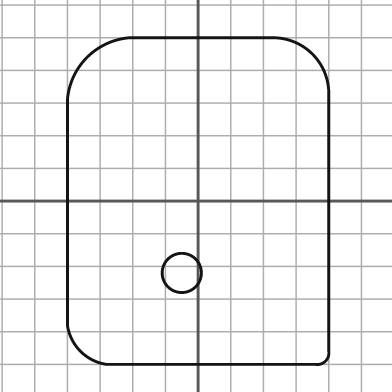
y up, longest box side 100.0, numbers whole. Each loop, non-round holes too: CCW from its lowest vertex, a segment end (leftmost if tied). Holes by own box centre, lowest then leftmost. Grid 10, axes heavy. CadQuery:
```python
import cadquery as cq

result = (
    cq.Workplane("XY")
    .moveTo(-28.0, -50.0)
    .lineTo(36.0, -50.0)
    .threePointArc((39.0, -49.0), (40.0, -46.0))
    .lineTo(40.0, 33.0)
    .threePointArc((35.0, 45.0), (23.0, 50.0))
    .lineTo(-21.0, 50.0)
    .threePointArc((-34.0, 44.0), (-40.0, 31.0))
    .lineTo(-40.0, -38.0)
    .threePointArc((-36.0, -46.0), (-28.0, -50.0))
    .close()
    .moveTo(-5.0, -22.0)
    .circle(6.0)
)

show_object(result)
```